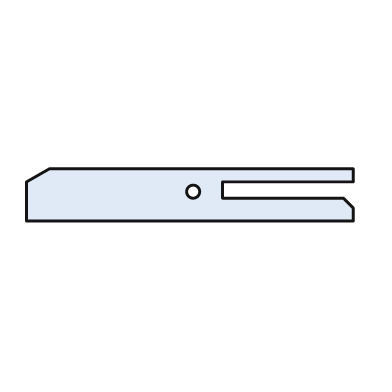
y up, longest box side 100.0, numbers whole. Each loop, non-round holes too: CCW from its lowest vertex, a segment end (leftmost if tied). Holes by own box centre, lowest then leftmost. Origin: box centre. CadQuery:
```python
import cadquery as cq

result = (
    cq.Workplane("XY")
    .moveTo(-50.0, -8.0)
    .lineTo(50.0, -8.0)
    .lineTo(50.0, -4.0)
    .lineTo(47.0, -1.0)
    .lineTo(10.0, -1.0)
    .lineTo(10.0, 4.0)
    .lineTo(50.0, 4.0)
    .lineTo(50.0, 8.0)
    .lineTo(-43.0, 8.0)
    .lineTo(-50.0, 4.0)
    .close()
    .moveTo(1.0, 1.0)
    .circle(2.0)
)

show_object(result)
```